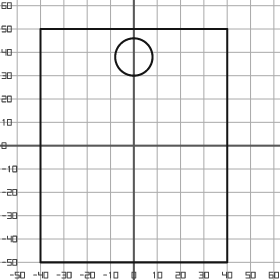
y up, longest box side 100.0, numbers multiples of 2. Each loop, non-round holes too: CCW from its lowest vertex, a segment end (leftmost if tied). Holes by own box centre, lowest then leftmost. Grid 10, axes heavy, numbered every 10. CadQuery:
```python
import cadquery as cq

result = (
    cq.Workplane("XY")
    .moveTo(-40.0, -50.0)
    .lineTo(40.0, -50.0)
    .lineTo(40.0, 50.0)
    .lineTo(-40.0, 50.0)
    .close()
    .moveTo(0.0, 38.0)
    .circle(8.0)
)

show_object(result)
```